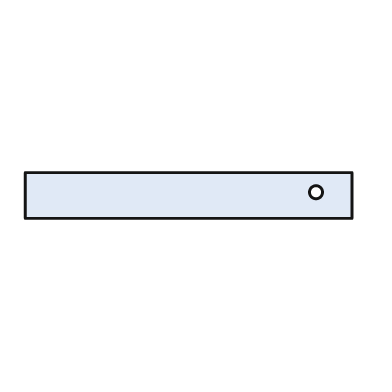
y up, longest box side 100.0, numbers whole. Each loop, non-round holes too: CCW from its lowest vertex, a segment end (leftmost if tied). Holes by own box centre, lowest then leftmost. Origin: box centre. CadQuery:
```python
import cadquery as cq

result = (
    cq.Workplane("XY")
    .moveTo(-50.0, -7.0)
    .lineTo(50.0, -7.0)
    .lineTo(50.0, 7.0)
    .lineTo(-50.0, 7.0)
    .close()
    .moveTo(39.0, 1.0)
    .circle(2.0)
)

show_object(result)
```